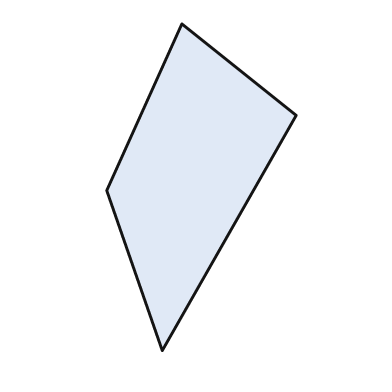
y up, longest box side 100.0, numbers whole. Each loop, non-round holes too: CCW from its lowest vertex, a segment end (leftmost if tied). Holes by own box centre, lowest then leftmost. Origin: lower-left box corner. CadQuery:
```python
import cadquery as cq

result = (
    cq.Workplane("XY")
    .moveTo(17.0, 0.0)
    .lineTo(58.0, 72.0)
    .lineTo(23.0, 100.0)
    .lineTo(0.0, 49.0)
    .close()
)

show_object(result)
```